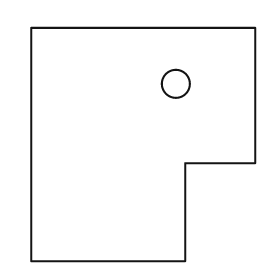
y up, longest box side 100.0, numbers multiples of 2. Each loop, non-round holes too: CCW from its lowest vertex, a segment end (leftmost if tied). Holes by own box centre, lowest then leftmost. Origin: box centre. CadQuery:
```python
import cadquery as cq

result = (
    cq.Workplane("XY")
    .moveTo(-48.0, -50.0)
    .lineTo(18.0, -50.0)
    .lineTo(18.0, -8.0)
    .lineTo(48.0, -8.0)
    .lineTo(48.0, 50.0)
    .lineTo(-48.0, 50.0)
    .close()
    .moveTo(14.0, 26.0)
    .circle(6.0)
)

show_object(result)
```